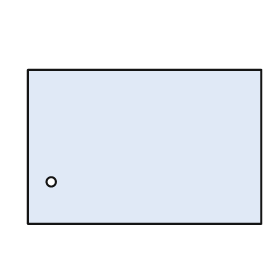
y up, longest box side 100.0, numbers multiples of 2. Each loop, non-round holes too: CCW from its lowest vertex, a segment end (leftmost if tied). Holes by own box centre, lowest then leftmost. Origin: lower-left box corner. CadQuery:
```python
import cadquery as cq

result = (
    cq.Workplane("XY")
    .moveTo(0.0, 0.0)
    .lineTo(100.0, 0.0)
    .lineTo(100.0, 66.0)
    .lineTo(0.0, 66.0)
    .close()
    .moveTo(10.0, 18.0)
    .circle(2.0)
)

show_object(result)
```